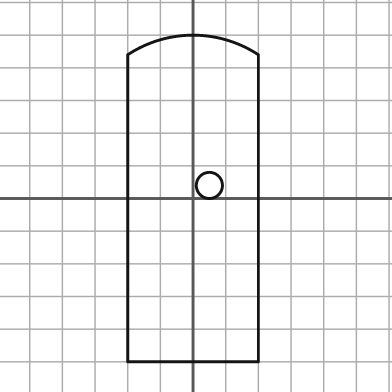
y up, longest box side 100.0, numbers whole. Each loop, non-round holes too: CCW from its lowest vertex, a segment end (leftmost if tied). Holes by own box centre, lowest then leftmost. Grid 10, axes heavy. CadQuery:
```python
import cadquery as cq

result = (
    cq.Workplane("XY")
    .moveTo(-20.0, -50.0)
    .lineTo(20.0, -50.0)
    .lineTo(20.0, 44.0)
    .threePointArc((0.0, 50.0), (-20.0, 44.0))
    .close()
    .moveTo(5.0, 4.0)
    .circle(4.0)
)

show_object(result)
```